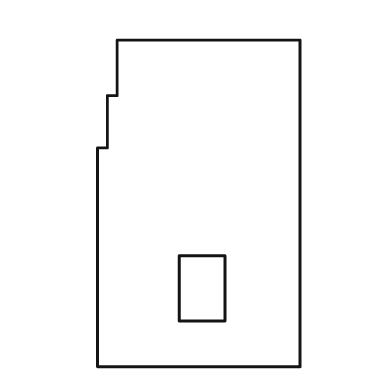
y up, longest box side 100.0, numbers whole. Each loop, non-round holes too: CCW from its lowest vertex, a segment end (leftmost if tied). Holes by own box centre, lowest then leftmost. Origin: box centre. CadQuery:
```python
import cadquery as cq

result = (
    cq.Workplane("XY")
    .moveTo(-31.0, -50.0)
    .lineTo(31.0, -50.0)
    .lineTo(31.0, 50.0)
    .lineTo(-25.0, 50.0)
    .lineTo(-25.0, 33.0)
    .lineTo(-28.0, 33.0)
    .lineTo(-28.0, 17.0)
    .lineTo(-31.0, 17.0)
    .close()
    .moveTo(-6.0, -36.0)
    .lineTo(8.0, -36.0)
    .lineTo(8.0, -16.0)
    .lineTo(-6.0, -16.0)
    .close()
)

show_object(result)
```